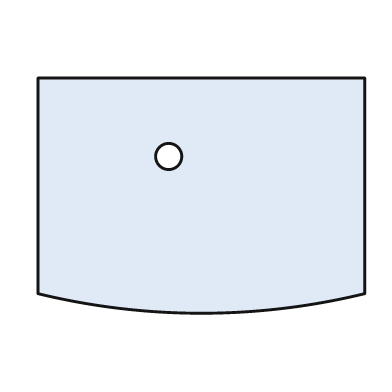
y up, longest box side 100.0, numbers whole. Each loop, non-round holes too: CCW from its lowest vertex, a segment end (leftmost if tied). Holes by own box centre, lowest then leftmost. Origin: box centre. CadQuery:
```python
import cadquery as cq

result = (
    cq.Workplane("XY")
    .moveTo(-50.0, -30.0)
    .threePointArc((0.0, -36.0), (50.0, -30.0))
    .lineTo(50.0, 36.0)
    .lineTo(-50.0, 36.0)
    .close()
    .moveTo(-10.0, 12.0)
    .circle(4.0)
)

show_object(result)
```